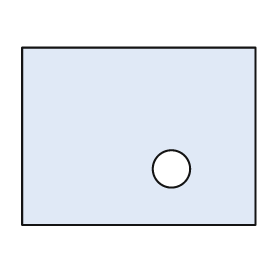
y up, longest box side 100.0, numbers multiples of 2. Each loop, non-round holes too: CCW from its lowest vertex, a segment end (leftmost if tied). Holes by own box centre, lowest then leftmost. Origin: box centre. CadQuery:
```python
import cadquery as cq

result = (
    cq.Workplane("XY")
    .moveTo(-50.0, -38.0)
    .lineTo(50.0, -38.0)
    .lineTo(50.0, 38.0)
    .lineTo(-50.0, 38.0)
    .close()
    .moveTo(14.0, -14.0)
    .circle(8.0)
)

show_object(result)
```